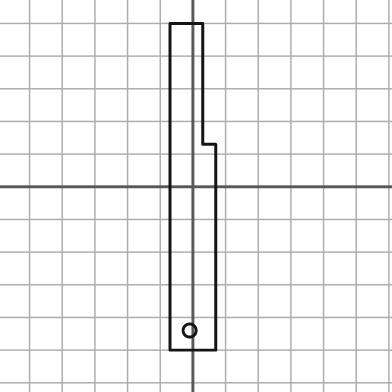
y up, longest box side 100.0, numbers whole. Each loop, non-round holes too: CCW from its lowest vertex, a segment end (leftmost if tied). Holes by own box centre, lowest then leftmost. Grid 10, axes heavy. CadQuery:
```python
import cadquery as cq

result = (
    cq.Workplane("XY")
    .moveTo(-7.0, -50.0)
    .lineTo(7.0, -50.0)
    .lineTo(7.0, 13.0)
    .lineTo(3.0, 13.0)
    .lineTo(3.0, 50.0)
    .lineTo(-7.0, 50.0)
    .close()
    .moveTo(-1.0, -44.0)
    .circle(2.0)
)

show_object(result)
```